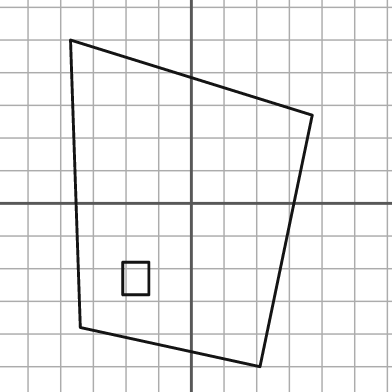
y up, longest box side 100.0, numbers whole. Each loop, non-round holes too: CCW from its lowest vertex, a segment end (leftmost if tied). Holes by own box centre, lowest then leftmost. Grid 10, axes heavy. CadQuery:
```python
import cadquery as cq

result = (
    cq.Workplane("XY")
    .moveTo(21.0, -50.0)
    .lineTo(37.0, 27.0)
    .lineTo(-37.0, 50.0)
    .lineTo(-34.0, -38.0)
    .close()
    .moveTo(-21.0, -28.0)
    .lineTo(-13.0, -28.0)
    .lineTo(-13.0, -18.0)
    .lineTo(-21.0, -18.0)
    .close()
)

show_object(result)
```